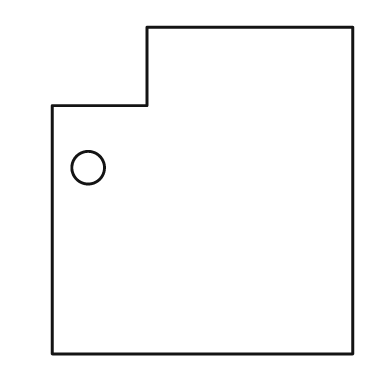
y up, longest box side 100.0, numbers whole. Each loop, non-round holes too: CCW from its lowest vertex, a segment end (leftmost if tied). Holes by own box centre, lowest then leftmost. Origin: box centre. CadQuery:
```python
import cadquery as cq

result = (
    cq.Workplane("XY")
    .moveTo(-46.0, -50.0)
    .lineTo(46.0, -50.0)
    .lineTo(46.0, 50.0)
    .lineTo(-17.0, 50.0)
    .lineTo(-17.0, 26.0)
    .lineTo(-46.0, 26.0)
    .close()
    .moveTo(-35.0, 7.0)
    .circle(5.0)
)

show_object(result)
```